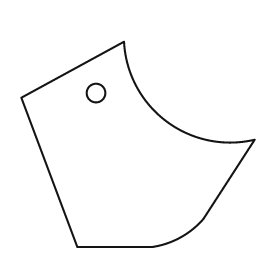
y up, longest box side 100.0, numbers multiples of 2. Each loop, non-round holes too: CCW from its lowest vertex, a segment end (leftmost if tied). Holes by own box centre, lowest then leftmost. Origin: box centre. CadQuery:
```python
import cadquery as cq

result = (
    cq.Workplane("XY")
    .moveTo(-26.0, -44.0)
    .lineTo(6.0, -44.0)
    .threePointArc((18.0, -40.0), (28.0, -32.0))
    .lineTo(50.0, 2.0)
    .threePointArc((12.0, 10.0), (-6.0, 44.0))
    .lineTo(-50.0, 20.0)
    .close()
    .moveTo(-18.0, 22.0)
    .circle(4.0)
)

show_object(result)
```